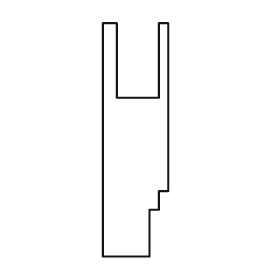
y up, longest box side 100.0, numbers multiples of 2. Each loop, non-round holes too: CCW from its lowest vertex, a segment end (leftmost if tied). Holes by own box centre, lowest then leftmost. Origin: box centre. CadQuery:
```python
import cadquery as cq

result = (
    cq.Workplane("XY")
    .moveTo(-14.0, -50.0)
    .lineTo(6.0, -50.0)
    .lineTo(6.0, -30.0)
    .lineTo(10.0, -30.0)
    .lineTo(10.0, -22.0)
    .lineTo(14.0, -22.0)
    .lineTo(14.0, 50.0)
    .lineTo(10.0, 50.0)
    .lineTo(10.0, 18.0)
    .lineTo(-8.0, 18.0)
    .lineTo(-8.0, 50.0)
    .lineTo(-14.0, 50.0)
    .close()
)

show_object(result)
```